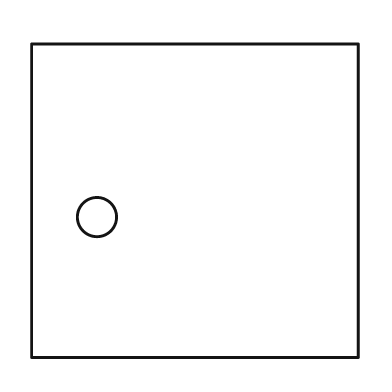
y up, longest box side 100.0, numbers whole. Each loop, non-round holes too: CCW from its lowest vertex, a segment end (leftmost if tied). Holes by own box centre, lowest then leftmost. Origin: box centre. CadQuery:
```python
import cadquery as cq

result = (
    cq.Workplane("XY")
    .moveTo(-50.0, -48.0)
    .lineTo(50.0, -48.0)
    .lineTo(50.0, 48.0)
    .lineTo(-50.0, 48.0)
    .close()
    .moveTo(-30.0, -5.0)
    .circle(6.0)
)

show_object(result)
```